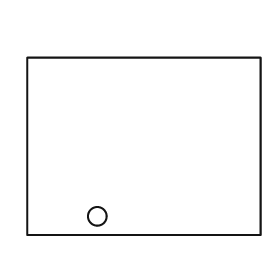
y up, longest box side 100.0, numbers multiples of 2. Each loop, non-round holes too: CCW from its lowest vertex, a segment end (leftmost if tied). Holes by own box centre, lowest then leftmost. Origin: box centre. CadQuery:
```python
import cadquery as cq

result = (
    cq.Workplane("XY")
    .moveTo(-50.0, -38.0)
    .lineTo(50.0, -38.0)
    .lineTo(50.0, 38.0)
    .lineTo(-50.0, 38.0)
    .close()
    .moveTo(-20.0, -30.0)
    .circle(4.0)
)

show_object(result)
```